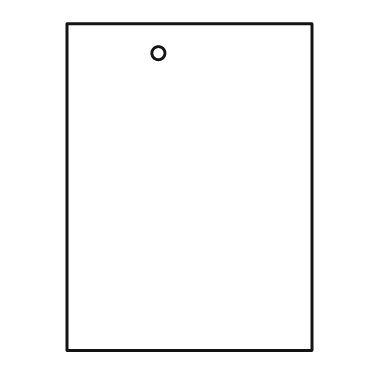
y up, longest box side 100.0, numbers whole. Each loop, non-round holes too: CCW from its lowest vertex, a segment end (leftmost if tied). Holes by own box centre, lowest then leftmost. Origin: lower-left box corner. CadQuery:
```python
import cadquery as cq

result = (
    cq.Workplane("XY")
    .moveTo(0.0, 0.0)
    .lineTo(75.0, 0.0)
    .lineTo(75.0, 100.0)
    .lineTo(0.0, 100.0)
    .close()
    .moveTo(28.0, 91.0)
    .circle(2.0)
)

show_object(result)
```